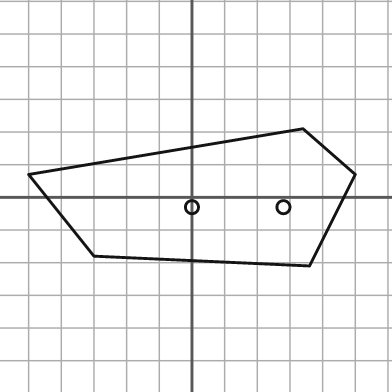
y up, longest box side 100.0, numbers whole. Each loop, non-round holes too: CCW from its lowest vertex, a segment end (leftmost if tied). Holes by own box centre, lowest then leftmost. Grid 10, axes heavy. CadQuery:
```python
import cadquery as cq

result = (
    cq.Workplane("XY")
    .moveTo(36.0, -21.0)
    .lineTo(50.0, 7.0)
    .lineTo(34.0, 21.0)
    .lineTo(-50.0, 7.0)
    .lineTo(-30.0, -18.0)
    .close()
    .moveTo(0.0, -3.0)
    .circle(2.0)
    .moveTo(28.0, -3.0)
    .circle(2.0)
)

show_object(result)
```